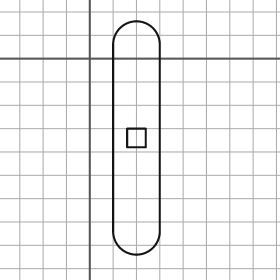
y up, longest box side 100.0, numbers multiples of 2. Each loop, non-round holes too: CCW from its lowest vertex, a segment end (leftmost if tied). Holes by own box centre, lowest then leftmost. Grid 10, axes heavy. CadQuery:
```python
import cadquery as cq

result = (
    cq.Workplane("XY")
    .moveTo(10.0, -74.0)
    .threePointArc((20.0, -84.0), (30.0, -74.0))
    .lineTo(30.0, 6.0)
    .threePointArc((20.0, 16.0), (10.0, 6.0))
    .close()
    .moveTo(16.0, -38.0)
    .lineTo(24.0, -38.0)
    .lineTo(24.0, -30.0)
    .lineTo(16.0, -30.0)
    .close()
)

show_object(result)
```